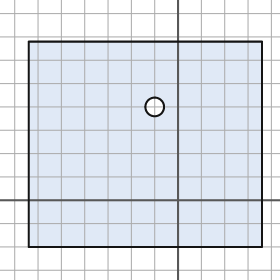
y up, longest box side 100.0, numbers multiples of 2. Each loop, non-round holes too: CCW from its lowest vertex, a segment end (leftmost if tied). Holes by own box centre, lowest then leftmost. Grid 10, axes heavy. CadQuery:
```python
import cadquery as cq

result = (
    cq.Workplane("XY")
    .moveTo(-64.0, -20.0)
    .lineTo(36.0, -20.0)
    .lineTo(36.0, 68.0)
    .lineTo(-64.0, 68.0)
    .close()
    .moveTo(-10.0, 40.0)
    .circle(4.0)
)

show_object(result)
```